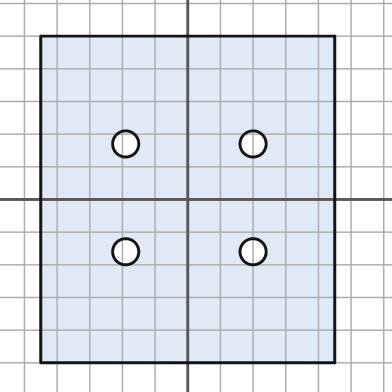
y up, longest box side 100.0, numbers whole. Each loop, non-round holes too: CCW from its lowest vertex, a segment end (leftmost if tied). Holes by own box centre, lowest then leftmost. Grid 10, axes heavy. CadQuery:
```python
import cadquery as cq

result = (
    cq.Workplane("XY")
    .moveTo(-45.0, -50.0)
    .lineTo(45.0, -50.0)
    .lineTo(45.0, 50.0)
    .lineTo(-45.0, 50.0)
    .close()
    .moveTo(-19.0, -16.0)
    .circle(4.0)
    .moveTo(20.0, -16.0)
    .circle(4.0)
    .moveTo(-19.0, 17.0)
    .circle(4.0)
    .moveTo(20.0, 17.0)
    .circle(4.0)
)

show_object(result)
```